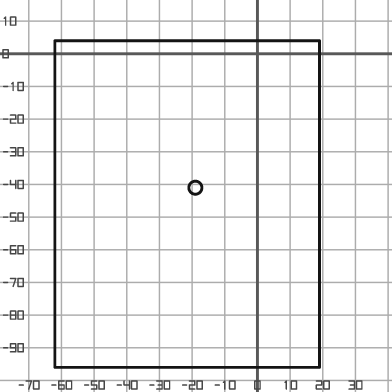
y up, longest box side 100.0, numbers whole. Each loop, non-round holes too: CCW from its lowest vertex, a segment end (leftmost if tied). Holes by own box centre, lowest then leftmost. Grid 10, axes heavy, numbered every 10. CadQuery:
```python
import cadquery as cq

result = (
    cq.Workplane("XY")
    .moveTo(-62.0, -96.0)
    .lineTo(19.0, -96.0)
    .lineTo(19.0, 4.0)
    .lineTo(-62.0, 4.0)
    .close()
    .moveTo(-19.0, -41.0)
    .circle(2.0)
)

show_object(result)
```